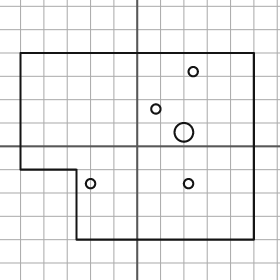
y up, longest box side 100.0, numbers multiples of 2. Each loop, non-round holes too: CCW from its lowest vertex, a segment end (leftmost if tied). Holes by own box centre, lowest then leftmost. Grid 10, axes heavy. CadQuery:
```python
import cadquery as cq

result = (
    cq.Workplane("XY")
    .moveTo(-26.0, -40.0)
    .lineTo(50.0, -40.0)
    .lineTo(50.0, 40.0)
    .lineTo(-50.0, 40.0)
    .lineTo(-50.0, -10.0)
    .lineTo(-26.0, -10.0)
    .close()
    .moveTo(-20.0, -16.0)
    .circle(2.0)
    .moveTo(22.0, -16.0)
    .circle(2.0)
    .moveTo(20.0, 6.0)
    .circle(4.0)
    .moveTo(8.0, 16.0)
    .circle(2.0)
    .moveTo(24.0, 32.0)
    .circle(2.0)
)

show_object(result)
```